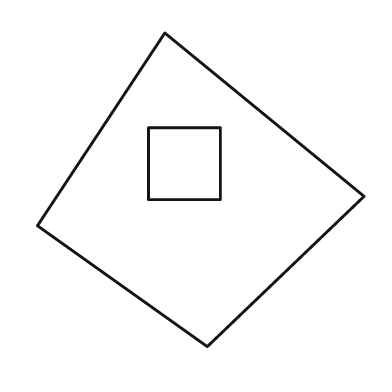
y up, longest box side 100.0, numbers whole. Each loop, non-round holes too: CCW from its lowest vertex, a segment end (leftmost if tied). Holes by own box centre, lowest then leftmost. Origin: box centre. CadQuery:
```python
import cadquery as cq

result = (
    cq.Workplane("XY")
    .moveTo(2.0, -48.0)
    .lineTo(50.0, -2.0)
    .lineTo(-11.0, 48.0)
    .lineTo(-50.0, -11.0)
    .close()
    .moveTo(-16.0, -3.0)
    .lineTo(6.0, -3.0)
    .lineTo(6.0, 19.0)
    .lineTo(-16.0, 19.0)
    .close()
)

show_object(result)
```